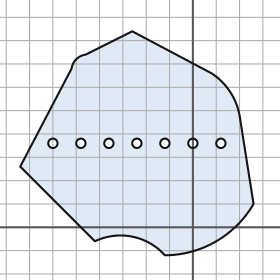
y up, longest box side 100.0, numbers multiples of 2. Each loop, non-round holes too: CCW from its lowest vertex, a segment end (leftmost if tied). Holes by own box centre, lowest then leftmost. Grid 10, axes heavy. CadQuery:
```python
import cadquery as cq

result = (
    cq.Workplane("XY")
    .moveTo(-12.0, -12.0)
    .threePointArc((10.0, -6.0), (26.0, 10.0))
    .lineTo(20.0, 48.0)
    .threePointArc((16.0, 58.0), (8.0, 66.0))
    .lineTo(-26.0, 84.0)
    .lineTo(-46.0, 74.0)
    .threePointArc((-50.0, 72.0), (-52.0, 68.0))
    .lineTo(-74.0, 26.0)
    .lineTo(-42.0, -6.0)
    .threePointArc((-26.0, -4.0), (-12.0, -12.0))
    .close()
    .moveTo(-60.0, 36.0)
    .circle(2.0)
    .moveTo(-48.0, 36.0)
    .circle(2.0)
    .moveTo(-36.0, 36.0)
    .circle(2.0)
    .moveTo(-24.0, 36.0)
    .circle(2.0)
    .moveTo(-12.0, 36.0)
    .circle(2.0)
    .moveTo(0.0, 36.0)
    .circle(2.0)
    .moveTo(12.0, 36.0)
    .circle(2.0)
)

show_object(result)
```